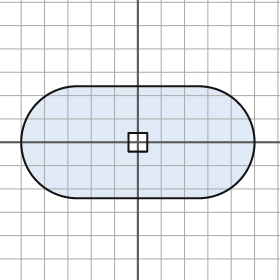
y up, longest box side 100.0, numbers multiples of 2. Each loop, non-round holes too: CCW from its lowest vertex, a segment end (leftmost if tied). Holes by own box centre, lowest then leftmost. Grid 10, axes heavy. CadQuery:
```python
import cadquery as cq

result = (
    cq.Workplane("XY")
    .moveTo(-26.0, -24.0)
    .lineTo(26.0, -24.0)
    .threePointArc((50.0, 0.0), (26.0, 24.0))
    .lineTo(-26.0, 24.0)
    .threePointArc((-50.0, 0.0), (-26.0, -24.0))
    .close()
    .moveTo(-4.0, -4.0)
    .lineTo(4.0, -4.0)
    .lineTo(4.0, 4.0)
    .lineTo(-4.0, 4.0)
    .close()
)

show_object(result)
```